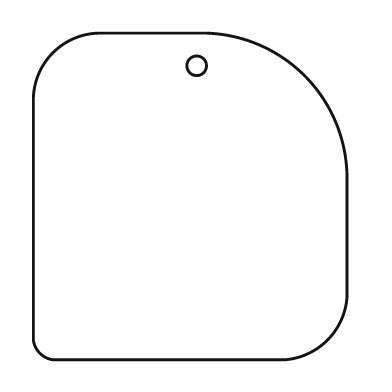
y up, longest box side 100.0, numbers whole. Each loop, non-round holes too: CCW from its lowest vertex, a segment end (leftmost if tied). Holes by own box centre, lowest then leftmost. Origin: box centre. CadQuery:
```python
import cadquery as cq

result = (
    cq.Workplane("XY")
    .moveTo(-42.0, -50.0)
    .lineTo(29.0, -50.0)
    .threePointArc((42.0, -44.0), (48.0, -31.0))
    .lineTo(48.0, 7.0)
    .threePointArc((35.0, 37.0), (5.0, 50.0))
    .lineTo(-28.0, 50.0)
    .threePointArc((-42.0, 44.0), (-48.0, 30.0))
    .lineTo(-48.0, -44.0)
    .threePointArc((-46.0, -48.0), (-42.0, -50.0))
    .close()
    .moveTo(2.0, 40.0)
    .circle(3.0)
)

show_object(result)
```